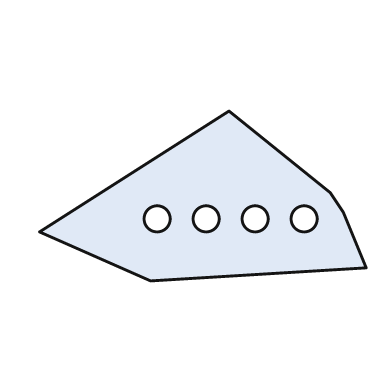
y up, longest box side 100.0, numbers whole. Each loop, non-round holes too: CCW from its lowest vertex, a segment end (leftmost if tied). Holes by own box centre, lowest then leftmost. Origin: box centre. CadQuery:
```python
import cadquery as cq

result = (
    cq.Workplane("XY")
    .moveTo(-16.0, -26.0)
    .lineTo(50.0, -22.0)
    .lineTo(43.0, -5.0)
    .lineTo(39.0, 1.0)
    .lineTo(8.0, 26.0)
    .lineTo(-50.0, -11.0)
    .close()
    .moveTo(-14.0, -7.0)
    .circle(4.0)
    .moveTo(1.0, -7.0)
    .circle(4.0)
    .moveTo(16.0, -7.0)
    .circle(4.0)
    .moveTo(31.0, -7.0)
    .circle(4.0)
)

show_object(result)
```